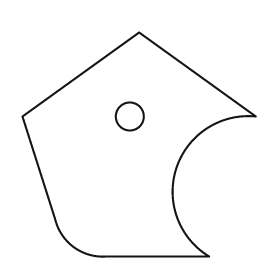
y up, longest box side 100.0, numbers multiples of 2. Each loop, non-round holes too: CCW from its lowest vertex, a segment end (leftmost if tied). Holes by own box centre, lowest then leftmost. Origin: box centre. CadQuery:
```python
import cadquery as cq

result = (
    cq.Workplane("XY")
    .moveTo(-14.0, -48.0)
    .lineTo(30.0, -48.0)
    .threePointArc((16.0, -10.0), (50.0, 12.0))
    .lineTo(0.0, 48.0)
    .lineTo(-50.0, 12.0)
    .lineTo(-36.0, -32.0)
    .threePointArc((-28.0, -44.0), (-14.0, -48.0))
    .close()
    .moveTo(-4.0, 12.0)
    .circle(6.0)
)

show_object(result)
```